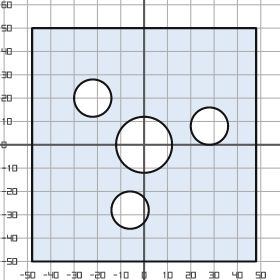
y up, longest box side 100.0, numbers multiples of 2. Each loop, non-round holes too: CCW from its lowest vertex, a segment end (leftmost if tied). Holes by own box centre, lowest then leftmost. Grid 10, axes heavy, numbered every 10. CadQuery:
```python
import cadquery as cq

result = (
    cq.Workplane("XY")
    .moveTo(-48.0, -50.0)
    .lineTo(48.0, -50.0)
    .lineTo(48.0, 50.0)
    .lineTo(-48.0, 50.0)
    .close()
    .moveTo(-6.0, -28.0)
    .circle(8.0)
    .moveTo(0.0, 0.0)
    .circle(12.0)
    .moveTo(28.0, 8.0)
    .circle(8.0)
    .moveTo(-22.0, 20.0)
    .circle(8.0)
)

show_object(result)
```